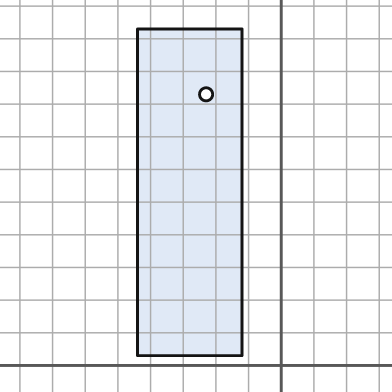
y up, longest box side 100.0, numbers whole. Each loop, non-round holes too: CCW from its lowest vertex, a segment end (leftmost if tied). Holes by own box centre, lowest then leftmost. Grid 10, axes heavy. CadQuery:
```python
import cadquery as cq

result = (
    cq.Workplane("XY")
    .moveTo(-44.0, 3.0)
    .lineTo(-12.0, 3.0)
    .lineTo(-12.0, 103.0)
    .lineTo(-44.0, 103.0)
    .close()
    .moveTo(-23.0, 83.0)
    .circle(2.0)
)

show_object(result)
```